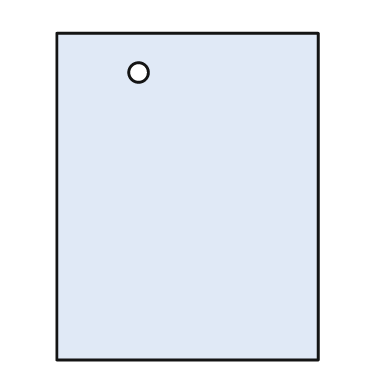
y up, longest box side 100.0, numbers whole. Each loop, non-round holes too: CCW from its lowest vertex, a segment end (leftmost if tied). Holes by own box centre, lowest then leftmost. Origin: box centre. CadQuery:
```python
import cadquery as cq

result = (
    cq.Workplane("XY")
    .moveTo(-40.0, -50.0)
    .lineTo(40.0, -50.0)
    .lineTo(40.0, 50.0)
    .lineTo(-40.0, 50.0)
    .close()
    .moveTo(-15.0, 38.0)
    .circle(3.0)
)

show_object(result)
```